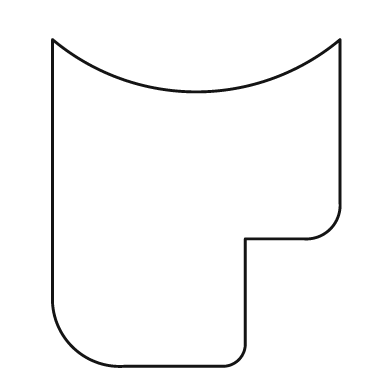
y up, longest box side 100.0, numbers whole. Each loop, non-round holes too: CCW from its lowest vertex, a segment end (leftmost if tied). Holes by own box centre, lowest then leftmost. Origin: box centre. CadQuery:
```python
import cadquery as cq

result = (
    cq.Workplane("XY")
    .moveTo(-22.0, -50.0)
    .lineTo(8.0, -50.0)
    .threePointArc((13.0, -48.0), (15.0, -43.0))
    .lineTo(15.0, -11.0)
    .lineTo(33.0, -11.0)
    .threePointArc((41.0, -8.0), (44.0, 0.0))
    .lineTo(44.0, 50.0)
    .threePointArc((0.0, 34.0), (-44.0, 50.0))
    .lineTo(-44.0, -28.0)
    .threePointArc((-38.0, -44.0), (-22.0, -50.0))
    .close()
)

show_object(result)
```